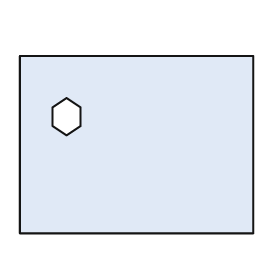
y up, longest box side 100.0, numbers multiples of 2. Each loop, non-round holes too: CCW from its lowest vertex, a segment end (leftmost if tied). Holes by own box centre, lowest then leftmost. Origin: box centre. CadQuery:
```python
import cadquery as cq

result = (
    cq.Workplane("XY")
    .moveTo(-50.0, -38.0)
    .lineTo(50.0, -38.0)
    .lineTo(50.0, 38.0)
    .lineTo(-50.0, 38.0)
    .close()
    .moveTo(-30.0, 4.0)
    .lineTo(-24.0, 8.0)
    .lineTo(-24.0, 16.0)
    .lineTo(-30.0, 20.0)
    .lineTo(-36.0, 16.0)
    .lineTo(-36.0, 8.0)
    .close()
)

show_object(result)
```